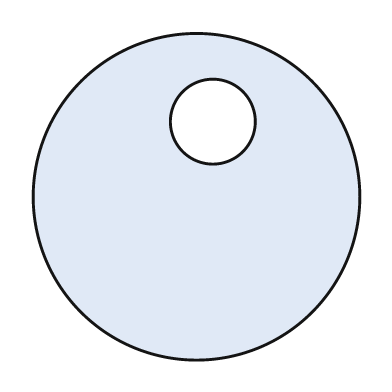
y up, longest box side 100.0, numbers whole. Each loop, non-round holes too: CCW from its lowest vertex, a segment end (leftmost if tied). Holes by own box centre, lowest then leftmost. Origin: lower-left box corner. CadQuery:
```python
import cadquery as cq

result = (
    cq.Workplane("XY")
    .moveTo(50.0, 50.0)
    .circle(50.0)
    .moveTo(55.0, 73.0)
    .circle(13.0)
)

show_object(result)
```